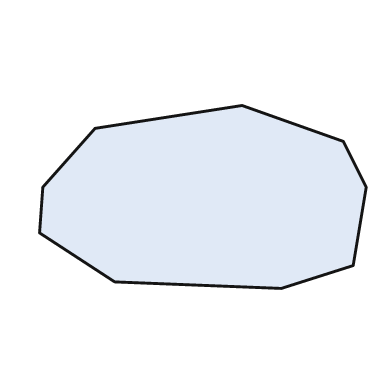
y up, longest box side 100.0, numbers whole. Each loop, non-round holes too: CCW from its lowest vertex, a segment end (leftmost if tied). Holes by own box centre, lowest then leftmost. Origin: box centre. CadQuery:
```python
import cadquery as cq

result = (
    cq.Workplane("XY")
    .moveTo(24.0, -28.0)
    .lineTo(46.0, -21.0)
    .lineTo(50.0, 3.0)
    .lineTo(43.0, 17.0)
    .lineTo(12.0, 28.0)
    .lineTo(-33.0, 21.0)
    .lineTo(-49.0, 3.0)
    .lineTo(-50.0, -11.0)
    .lineTo(-27.0, -26.0)
    .close()
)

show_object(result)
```